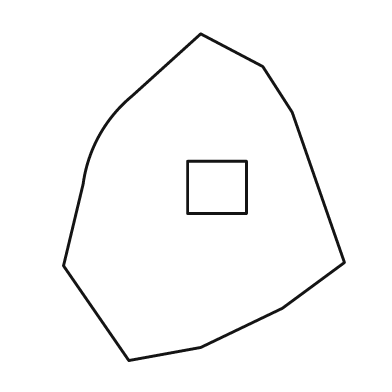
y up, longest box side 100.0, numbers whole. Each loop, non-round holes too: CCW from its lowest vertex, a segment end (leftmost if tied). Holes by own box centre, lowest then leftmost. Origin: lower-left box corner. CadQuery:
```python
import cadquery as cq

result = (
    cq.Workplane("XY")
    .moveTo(20.0, 0.0)
    .lineTo(42.0, 4.0)
    .lineTo(67.0, 16.0)
    .lineTo(86.0, 30.0)
    .lineTo(70.0, 76.0)
    .lineTo(61.0, 90.0)
    .lineTo(42.0, 100.0)
    .lineTo(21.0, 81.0)
    .threePointArc((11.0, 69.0), (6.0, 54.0))
    .lineTo(0.0, 29.0)
    .close()
    .moveTo(38.0, 45.0)
    .lineTo(56.0, 45.0)
    .lineTo(56.0, 61.0)
    .lineTo(38.0, 61.0)
    .close()
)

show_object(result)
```